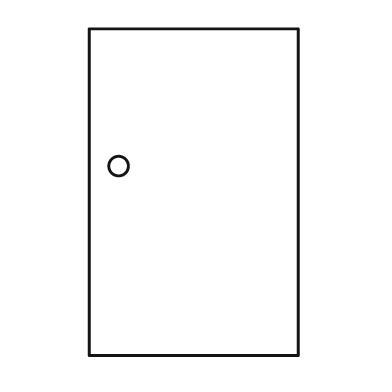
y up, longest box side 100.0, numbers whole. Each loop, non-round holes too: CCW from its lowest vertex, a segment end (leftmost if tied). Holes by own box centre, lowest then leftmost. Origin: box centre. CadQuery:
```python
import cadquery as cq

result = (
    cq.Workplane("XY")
    .moveTo(-32.0, -50.0)
    .lineTo(32.0, -50.0)
    .lineTo(32.0, 50.0)
    .lineTo(-32.0, 50.0)
    .close()
    .moveTo(-23.0, 8.0)
    .circle(3.0)
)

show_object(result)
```